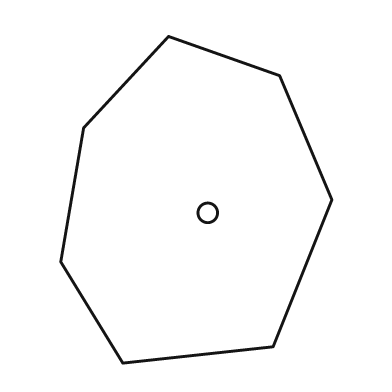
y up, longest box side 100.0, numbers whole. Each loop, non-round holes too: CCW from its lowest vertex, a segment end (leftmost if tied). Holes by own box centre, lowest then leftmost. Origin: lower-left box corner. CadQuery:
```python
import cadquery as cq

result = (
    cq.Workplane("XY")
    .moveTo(19.0, 0.0)
    .lineTo(65.0, 5.0)
    .lineTo(83.0, 50.0)
    .lineTo(67.0, 88.0)
    .lineTo(33.0, 100.0)
    .lineTo(7.0, 72.0)
    .lineTo(0.0, 31.0)
    .close()
    .moveTo(45.0, 46.0)
    .circle(3.0)
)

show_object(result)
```